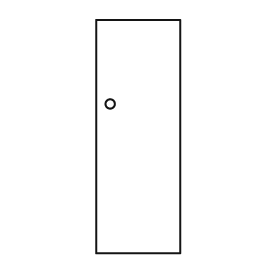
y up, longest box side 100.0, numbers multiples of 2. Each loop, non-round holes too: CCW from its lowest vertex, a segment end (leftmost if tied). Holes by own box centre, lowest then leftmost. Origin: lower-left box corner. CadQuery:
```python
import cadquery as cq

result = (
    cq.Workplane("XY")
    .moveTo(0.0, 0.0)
    .lineTo(36.0, 0.0)
    .lineTo(36.0, 100.0)
    .lineTo(0.0, 100.0)
    .close()
    .moveTo(6.0, 64.0)
    .circle(2.0)
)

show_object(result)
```